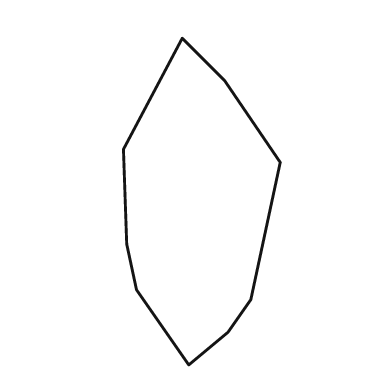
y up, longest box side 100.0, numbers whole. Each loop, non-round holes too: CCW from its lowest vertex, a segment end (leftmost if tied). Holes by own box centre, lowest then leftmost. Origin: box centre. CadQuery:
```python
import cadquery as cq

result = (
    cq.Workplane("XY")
    .moveTo(-4.0, -50.0)
    .lineTo(8.0, -40.0)
    .lineTo(15.0, -30.0)
    .lineTo(24.0, 12.0)
    .lineTo(7.0, 37.0)
    .lineTo(-6.0, 50.0)
    .lineTo(-24.0, 16.0)
    .lineTo(-23.0, -13.0)
    .lineTo(-20.0, -27.0)
    .close()
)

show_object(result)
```